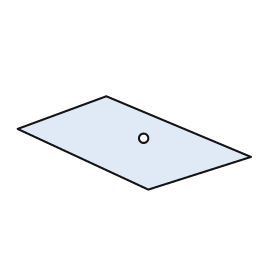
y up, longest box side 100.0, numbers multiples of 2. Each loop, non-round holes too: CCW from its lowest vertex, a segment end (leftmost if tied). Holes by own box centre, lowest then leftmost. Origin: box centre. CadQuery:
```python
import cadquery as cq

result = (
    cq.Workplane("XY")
    .moveTo(6.0, -20.0)
    .lineTo(50.0, -6.0)
    .lineTo(-12.0, 20.0)
    .lineTo(-50.0, 6.0)
    .close()
    .moveTo(4.0, 2.0)
    .circle(2.0)
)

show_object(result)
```